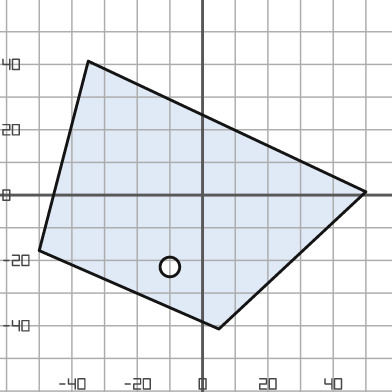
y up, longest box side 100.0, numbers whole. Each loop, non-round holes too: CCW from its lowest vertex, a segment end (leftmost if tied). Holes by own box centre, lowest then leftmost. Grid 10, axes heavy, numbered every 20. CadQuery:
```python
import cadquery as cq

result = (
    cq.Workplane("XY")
    .moveTo(5.0, -41.0)
    .lineTo(50.0, 1.0)
    .lineTo(-35.0, 41.0)
    .lineTo(-50.0, -17.0)
    .close()
    .moveTo(-10.0, -22.0)
    .circle(3.0)
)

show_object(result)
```